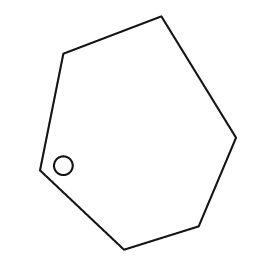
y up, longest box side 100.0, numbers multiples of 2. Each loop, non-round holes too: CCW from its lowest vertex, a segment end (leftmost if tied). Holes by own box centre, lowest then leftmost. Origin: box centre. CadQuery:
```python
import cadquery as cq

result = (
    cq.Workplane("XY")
    .moveTo(-6.0, -50.0)
    .lineTo(26.0, -40.0)
    .lineTo(42.0, -2.0)
    .lineTo(10.0, 50.0)
    .lineTo(-32.0, 34.0)
    .lineTo(-42.0, -16.0)
    .close()
    .moveTo(-32.0, -14.0)
    .circle(4.0)
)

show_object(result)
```